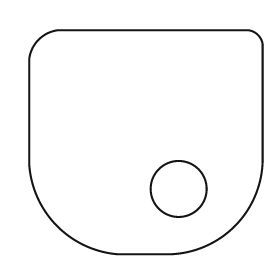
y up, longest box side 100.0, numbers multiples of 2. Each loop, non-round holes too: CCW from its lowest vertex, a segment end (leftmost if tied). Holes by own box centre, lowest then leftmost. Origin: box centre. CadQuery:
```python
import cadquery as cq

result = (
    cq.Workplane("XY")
    .moveTo(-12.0, -48.0)
    .lineTo(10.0, -48.0)
    .threePointArc((38.0, -36.0), (50.0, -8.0))
    .lineTo(50.0, 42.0)
    .threePointArc((48.0, 46.0), (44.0, 48.0))
    .lineTo(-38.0, 48.0)
    .threePointArc((-46.0, 44.0), (-50.0, 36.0))
    .lineTo(-50.0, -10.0)
    .threePointArc((-38.0, -36.0), (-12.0, -48.0))
    .close()
    .moveTo(14.0, -20.0)
    .circle(12.0)
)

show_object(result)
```